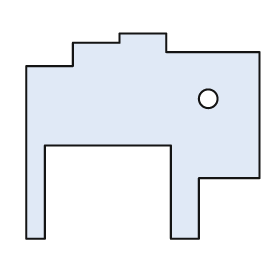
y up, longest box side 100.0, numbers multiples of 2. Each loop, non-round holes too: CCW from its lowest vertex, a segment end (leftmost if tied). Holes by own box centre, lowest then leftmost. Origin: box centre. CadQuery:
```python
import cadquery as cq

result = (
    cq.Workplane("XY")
    .moveTo(-50.0, -44.0)
    .lineTo(-42.0, -44.0)
    .lineTo(-42.0, -4.0)
    .lineTo(12.0, -4.0)
    .lineTo(12.0, -44.0)
    .lineTo(24.0, -44.0)
    .lineTo(24.0, -18.0)
    .lineTo(50.0, -18.0)
    .lineTo(50.0, 36.0)
    .lineTo(10.0, 36.0)
    .lineTo(10.0, 44.0)
    .lineTo(-10.0, 44.0)
    .lineTo(-10.0, 40.0)
    .lineTo(-30.0, 40.0)
    .lineTo(-30.0, 30.0)
    .lineTo(-50.0, 30.0)
    .close()
    .moveTo(28.0, 16.0)
    .circle(4.0)
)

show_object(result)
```